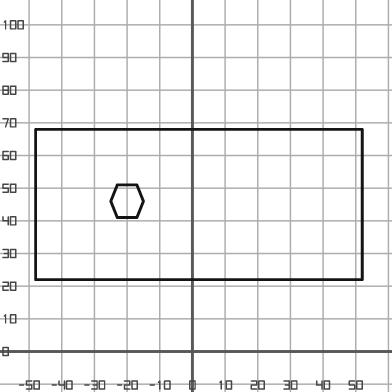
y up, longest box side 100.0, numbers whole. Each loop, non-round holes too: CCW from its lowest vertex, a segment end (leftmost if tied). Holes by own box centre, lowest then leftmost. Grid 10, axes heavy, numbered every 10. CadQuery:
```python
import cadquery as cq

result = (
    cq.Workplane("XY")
    .moveTo(-48.0, 22.0)
    .lineTo(52.0, 22.0)
    .lineTo(52.0, 68.0)
    .lineTo(-48.0, 68.0)
    .close()
    .moveTo(-23.0, 41.0)
    .lineTo(-17.0, 41.0)
    .lineTo(-15.0, 46.0)
    .lineTo(-17.0, 51.0)
    .lineTo(-23.0, 51.0)
    .lineTo(-25.0, 46.0)
    .close()
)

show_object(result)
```